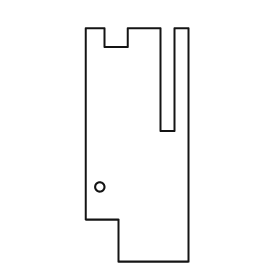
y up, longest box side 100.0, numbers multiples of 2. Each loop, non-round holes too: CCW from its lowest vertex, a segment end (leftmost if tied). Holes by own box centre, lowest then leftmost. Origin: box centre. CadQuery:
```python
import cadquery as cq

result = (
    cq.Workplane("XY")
    .moveTo(-8.0, -50.0)
    .lineTo(22.0, -50.0)
    .lineTo(22.0, 50.0)
    .lineTo(16.0, 50.0)
    .lineTo(16.0, 6.0)
    .lineTo(10.0, 6.0)
    .lineTo(10.0, 50.0)
    .lineTo(-4.0, 50.0)
    .lineTo(-4.0, 42.0)
    .lineTo(-14.0, 42.0)
    .lineTo(-14.0, 50.0)
    .lineTo(-22.0, 50.0)
    .lineTo(-22.0, -32.0)
    .lineTo(-8.0, -32.0)
    .close()
    .moveTo(-16.0, -18.0)
    .circle(2.0)
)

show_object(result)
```